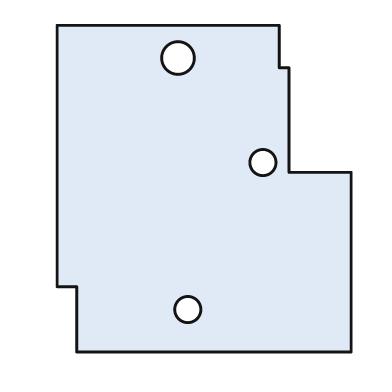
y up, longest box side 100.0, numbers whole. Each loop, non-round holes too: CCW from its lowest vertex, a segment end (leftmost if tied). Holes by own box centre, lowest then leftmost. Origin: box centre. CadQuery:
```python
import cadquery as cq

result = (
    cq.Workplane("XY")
    .moveTo(-39.0, -50.0)
    .lineTo(45.0, -50.0)
    .lineTo(45.0, 5.0)
    .lineTo(26.0, 5.0)
    .lineTo(26.0, 37.0)
    .lineTo(23.0, 37.0)
    .lineTo(23.0, 50.0)
    .lineTo(-45.0, 50.0)
    .lineTo(-45.0, -30.0)
    .lineTo(-39.0, -30.0)
    .close()
    .moveTo(-5.0, -37.0)
    .circle(4.0)
    .moveTo(18.0, 8.0)
    .circle(4.0)
    .moveTo(-8.0, 40.0)
    .circle(5.0)
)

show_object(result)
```